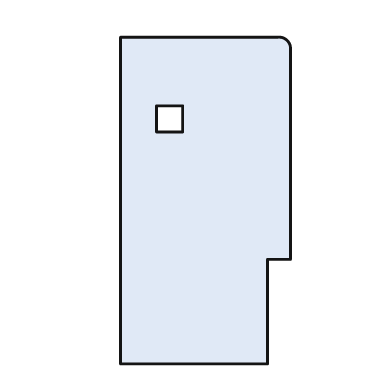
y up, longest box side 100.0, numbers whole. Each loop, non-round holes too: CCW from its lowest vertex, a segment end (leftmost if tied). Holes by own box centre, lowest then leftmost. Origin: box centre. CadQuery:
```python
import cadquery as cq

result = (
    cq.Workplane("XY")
    .moveTo(-26.0, -50.0)
    .lineTo(19.0, -50.0)
    .lineTo(19.0, -18.0)
    .lineTo(26.0, -18.0)
    .lineTo(26.0, 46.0)
    .threePointArc((25.0, 49.0), (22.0, 50.0))
    .lineTo(-26.0, 50.0)
    .close()
    .moveTo(-15.0, 21.0)
    .lineTo(-7.0, 21.0)
    .lineTo(-7.0, 29.0)
    .lineTo(-15.0, 29.0)
    .close()
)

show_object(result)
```